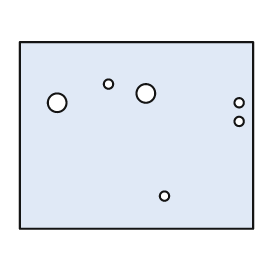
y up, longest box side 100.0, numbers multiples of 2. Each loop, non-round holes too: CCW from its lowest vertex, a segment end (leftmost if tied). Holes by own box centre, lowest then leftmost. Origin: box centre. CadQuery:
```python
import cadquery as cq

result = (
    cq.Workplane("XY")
    .moveTo(-50.0, -40.0)
    .lineTo(50.0, -40.0)
    .lineTo(50.0, 40.0)
    .lineTo(-50.0, 40.0)
    .close()
    .moveTo(12.0, -26.0)
    .circle(2.0)
    .moveTo(44.0, 6.0)
    .circle(2.0)
    .moveTo(-34.0, 14.0)
    .circle(4.0)
    .moveTo(44.0, 14.0)
    .circle(2.0)
    .moveTo(4.0, 18.0)
    .circle(4.0)
    .moveTo(-12.0, 22.0)
    .circle(2.0)
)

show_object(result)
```